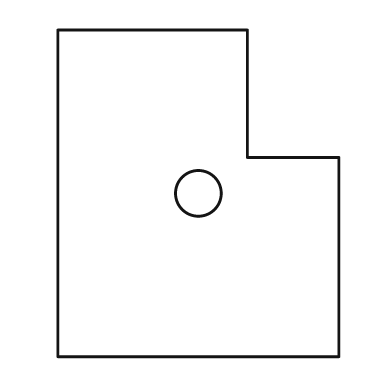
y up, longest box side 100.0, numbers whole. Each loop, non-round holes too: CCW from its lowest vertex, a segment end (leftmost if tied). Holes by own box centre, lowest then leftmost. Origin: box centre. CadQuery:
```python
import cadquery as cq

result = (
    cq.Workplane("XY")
    .moveTo(-43.0, -50.0)
    .lineTo(43.0, -50.0)
    .lineTo(43.0, 11.0)
    .lineTo(15.0, 11.0)
    .lineTo(15.0, 50.0)
    .lineTo(-43.0, 50.0)
    .close()
    .moveTo(0.0, 0.0)
    .circle(7.0)
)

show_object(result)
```